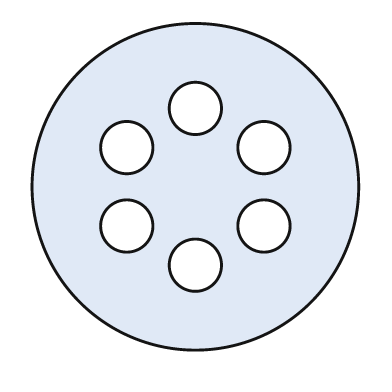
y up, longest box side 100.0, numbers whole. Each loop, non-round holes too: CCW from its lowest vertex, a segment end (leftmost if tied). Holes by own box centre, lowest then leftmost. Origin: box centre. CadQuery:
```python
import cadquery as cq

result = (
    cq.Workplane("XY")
    .moveTo(0.0, 0.0)
    .circle(50.0)
    .moveTo(0.0, -24.0)
    .circle(8.0)
    .moveTo(-21.0, -12.0)
    .circle(8.0)
    .moveTo(21.0, -12.0)
    .circle(8.0)
    .moveTo(-21.0, 12.0)
    .circle(8.0)
    .moveTo(21.0, 12.0)
    .circle(8.0)
    .moveTo(0.0, 24.0)
    .circle(8.0)
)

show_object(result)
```